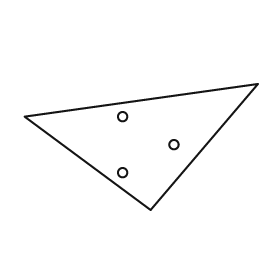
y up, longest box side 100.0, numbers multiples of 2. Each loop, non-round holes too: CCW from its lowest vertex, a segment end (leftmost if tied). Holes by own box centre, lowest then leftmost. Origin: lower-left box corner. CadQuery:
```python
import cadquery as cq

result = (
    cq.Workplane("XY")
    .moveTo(54.0, 0.0)
    .lineTo(100.0, 54.0)
    .lineTo(0.0, 40.0)
    .close()
    .moveTo(42.0, 16.0)
    .circle(2.0)
    .moveTo(64.0, 28.0)
    .circle(2.0)
    .moveTo(42.0, 40.0)
    .circle(2.0)
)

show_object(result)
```